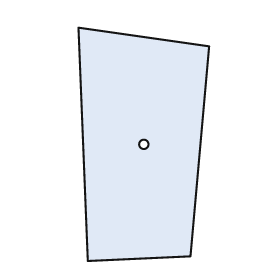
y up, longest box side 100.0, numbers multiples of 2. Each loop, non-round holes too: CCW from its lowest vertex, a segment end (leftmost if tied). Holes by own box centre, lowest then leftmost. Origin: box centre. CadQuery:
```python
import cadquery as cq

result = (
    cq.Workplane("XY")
    .moveTo(-24.0, -50.0)
    .lineTo(20.0, -48.0)
    .lineTo(28.0, 42.0)
    .lineTo(-28.0, 50.0)
    .close()
    .moveTo(0.0, 0.0)
    .circle(2.0)
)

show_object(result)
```